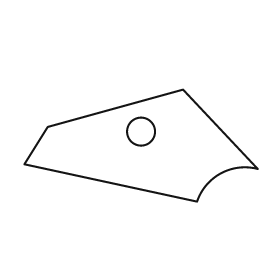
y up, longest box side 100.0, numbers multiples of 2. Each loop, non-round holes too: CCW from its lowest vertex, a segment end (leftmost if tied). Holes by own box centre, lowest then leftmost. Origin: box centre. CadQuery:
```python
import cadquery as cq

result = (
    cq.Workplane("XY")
    .moveTo(24.0, -24.0)
    .threePointArc((34.0, -12.0), (50.0, -10.0))
    .lineTo(18.0, 24.0)
    .lineTo(-40.0, 8.0)
    .lineTo(-50.0, -8.0)
    .close()
    .moveTo(0.0, 6.0)
    .circle(6.0)
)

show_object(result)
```